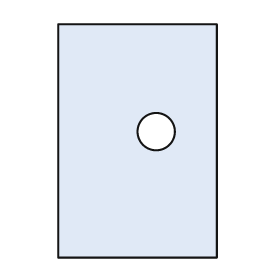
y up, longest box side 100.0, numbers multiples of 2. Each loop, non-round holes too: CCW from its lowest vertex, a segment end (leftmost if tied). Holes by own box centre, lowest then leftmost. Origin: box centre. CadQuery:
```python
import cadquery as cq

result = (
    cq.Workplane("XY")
    .moveTo(-34.0, -50.0)
    .lineTo(34.0, -50.0)
    .lineTo(34.0, 50.0)
    .lineTo(-34.0, 50.0)
    .close()
    .moveTo(8.0, 4.0)
    .circle(8.0)
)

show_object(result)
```